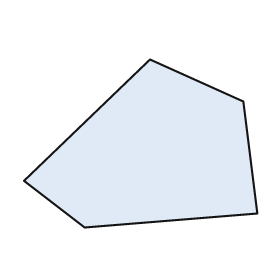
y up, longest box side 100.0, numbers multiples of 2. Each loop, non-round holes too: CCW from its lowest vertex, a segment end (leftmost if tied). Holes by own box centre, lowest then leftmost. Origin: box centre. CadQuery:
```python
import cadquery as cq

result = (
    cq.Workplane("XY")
    .moveTo(-24.0, -36.0)
    .lineTo(50.0, -30.0)
    .lineTo(44.0, 18.0)
    .lineTo(4.0, 36.0)
    .lineTo(-50.0, -16.0)
    .close()
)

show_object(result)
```